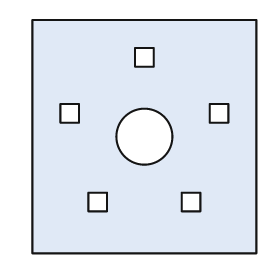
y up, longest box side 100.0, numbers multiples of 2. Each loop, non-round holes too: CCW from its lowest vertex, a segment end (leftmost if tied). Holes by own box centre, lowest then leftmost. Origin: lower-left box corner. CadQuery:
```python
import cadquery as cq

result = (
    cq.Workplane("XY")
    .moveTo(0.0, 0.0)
    .lineTo(96.0, 0.0)
    .lineTo(96.0, 100.0)
    .lineTo(0.0, 100.0)
    .close()
    .moveTo(24.0, 18.0)
    .lineTo(32.0, 18.0)
    .lineTo(32.0, 26.0)
    .lineTo(24.0, 26.0)
    .close()
    .moveTo(64.0, 18.0)
    .lineTo(72.0, 18.0)
    .lineTo(72.0, 26.0)
    .lineTo(64.0, 26.0)
    .close()
    .moveTo(48.0, 50.0)
    .circle(12.0)
    .moveTo(12.0, 56.0)
    .lineTo(20.0, 56.0)
    .lineTo(20.0, 64.0)
    .lineTo(12.0, 64.0)
    .close()
    .moveTo(76.0, 56.0)
    .lineTo(84.0, 56.0)
    .lineTo(84.0, 64.0)
    .lineTo(76.0, 64.0)
    .close()
    .moveTo(44.0, 80.0)
    .lineTo(52.0, 80.0)
    .lineTo(52.0, 88.0)
    .lineTo(44.0, 88.0)
    .close()
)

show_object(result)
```